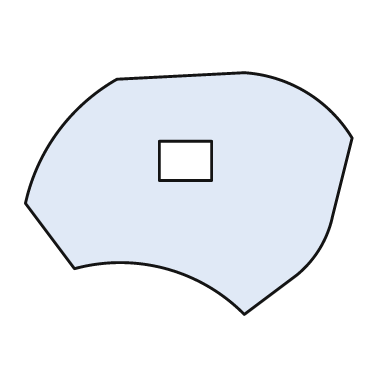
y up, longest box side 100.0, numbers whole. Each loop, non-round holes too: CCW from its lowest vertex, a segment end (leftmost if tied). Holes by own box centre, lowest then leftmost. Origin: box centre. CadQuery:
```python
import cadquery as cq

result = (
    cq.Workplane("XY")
    .moveTo(17.0, -37.0)
    .lineTo(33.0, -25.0)
    .threePointArc((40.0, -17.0), (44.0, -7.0))
    .lineTo(50.0, 17.0)
    .threePointArc((36.0, 31.0), (17.0, 37.0))
    .lineTo(-22.0, 35.0)
    .threePointArc((-40.0, 19.0), (-50.0, -3.0))
    .lineTo(-35.0, -23.0)
    .threePointArc((-7.0, -23.0), (17.0, -37.0))
    .close()
    .moveTo(-9.0, 4.0)
    .lineTo(7.0, 4.0)
    .lineTo(7.0, 16.0)
    .lineTo(-9.0, 16.0)
    .close()
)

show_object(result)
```